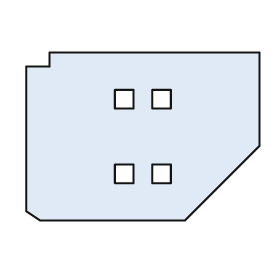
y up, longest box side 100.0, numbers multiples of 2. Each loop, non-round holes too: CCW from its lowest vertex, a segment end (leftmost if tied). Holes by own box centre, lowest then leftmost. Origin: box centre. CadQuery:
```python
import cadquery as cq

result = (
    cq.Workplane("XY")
    .moveTo(-44.0, -36.0)
    .lineTo(18.0, -36.0)
    .lineTo(50.0, -4.0)
    .lineTo(50.0, 36.0)
    .lineTo(-40.0, 36.0)
    .lineTo(-40.0, 30.0)
    .lineTo(-50.0, 30.0)
    .lineTo(-50.0, -32.0)
    .close()
    .moveTo(-12.0, -20.0)
    .lineTo(-4.0, -20.0)
    .lineTo(-4.0, -12.0)
    .lineTo(-12.0, -12.0)
    .close()
    .moveTo(4.0, -20.0)
    .lineTo(12.0, -20.0)
    .lineTo(12.0, -12.0)
    .lineTo(4.0, -12.0)
    .close()
    .moveTo(-12.0, 12.0)
    .lineTo(-4.0, 12.0)
    .lineTo(-4.0, 20.0)
    .lineTo(-12.0, 20.0)
    .close()
    .moveTo(4.0, 12.0)
    .lineTo(12.0, 12.0)
    .lineTo(12.0, 20.0)
    .lineTo(4.0, 20.0)
    .close()
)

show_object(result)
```